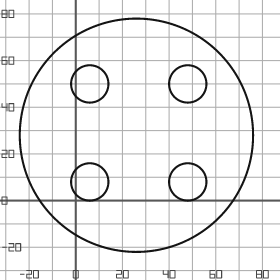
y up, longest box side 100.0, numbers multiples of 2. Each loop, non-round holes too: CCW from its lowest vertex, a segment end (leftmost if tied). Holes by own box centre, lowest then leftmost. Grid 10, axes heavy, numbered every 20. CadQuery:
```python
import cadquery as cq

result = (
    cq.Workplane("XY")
    .moveTo(26.0, 28.0)
    .circle(50.0)
    .moveTo(6.0, 8.0)
    .circle(8.0)
    .moveTo(48.0, 8.0)
    .circle(8.0)
    .moveTo(6.0, 50.0)
    .circle(8.0)
    .moveTo(48.0, 50.0)
    .circle(8.0)
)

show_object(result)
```